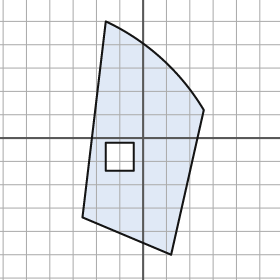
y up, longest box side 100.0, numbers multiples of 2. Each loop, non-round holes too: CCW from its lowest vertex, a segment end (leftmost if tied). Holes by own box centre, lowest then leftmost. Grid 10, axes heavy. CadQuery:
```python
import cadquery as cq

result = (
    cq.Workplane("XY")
    .moveTo(12.0, -50.0)
    .lineTo(26.0, 12.0)
    .threePointArc((8.0, 34.0), (-16.0, 50.0))
    .lineTo(-26.0, -34.0)
    .close()
    .moveTo(-16.0, -14.0)
    .lineTo(-4.0, -14.0)
    .lineTo(-4.0, -2.0)
    .lineTo(-16.0, -2.0)
    .close()
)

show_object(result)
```